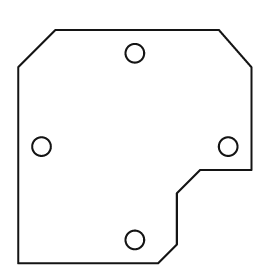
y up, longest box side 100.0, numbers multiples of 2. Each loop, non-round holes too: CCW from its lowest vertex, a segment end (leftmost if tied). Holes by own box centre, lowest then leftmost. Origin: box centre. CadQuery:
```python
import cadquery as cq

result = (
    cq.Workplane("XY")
    .moveTo(-50.0, -50.0)
    .lineTo(10.0, -50.0)
    .lineTo(18.0, -42.0)
    .lineTo(18.0, -20.0)
    .lineTo(28.0, -10.0)
    .lineTo(50.0, -10.0)
    .lineTo(50.0, 34.0)
    .lineTo(36.0, 50.0)
    .lineTo(-34.0, 50.0)
    .lineTo(-50.0, 34.0)
    .close()
    .moveTo(0.0, -40.0)
    .circle(4.0)
    .moveTo(-40.0, 0.0)
    .circle(4.0)
    .moveTo(40.0, 0.0)
    .circle(4.0)
    .moveTo(0.0, 40.0)
    .circle(4.0)
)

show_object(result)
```